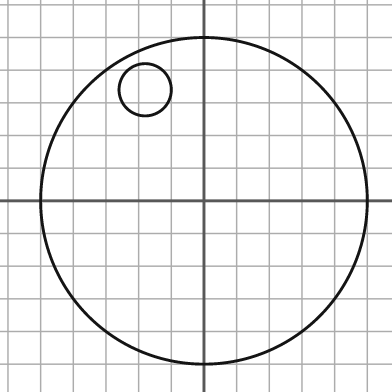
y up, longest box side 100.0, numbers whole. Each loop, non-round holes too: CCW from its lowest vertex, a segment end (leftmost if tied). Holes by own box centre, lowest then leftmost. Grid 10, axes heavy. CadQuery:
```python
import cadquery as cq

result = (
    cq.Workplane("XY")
    .moveTo(0.0, 0.0)
    .circle(50.0)
    .moveTo(-18.0, 34.0)
    .circle(8.0)
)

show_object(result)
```